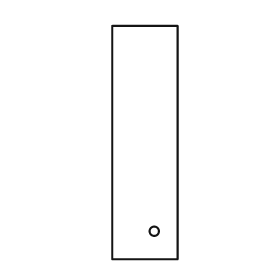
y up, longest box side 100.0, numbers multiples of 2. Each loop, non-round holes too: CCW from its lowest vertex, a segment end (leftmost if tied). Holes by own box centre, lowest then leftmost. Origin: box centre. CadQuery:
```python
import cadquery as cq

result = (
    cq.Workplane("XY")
    .moveTo(-14.0, -50.0)
    .lineTo(14.0, -50.0)
    .lineTo(14.0, 50.0)
    .lineTo(-14.0, 50.0)
    .close()
    .moveTo(4.0, -38.0)
    .circle(2.0)
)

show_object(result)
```